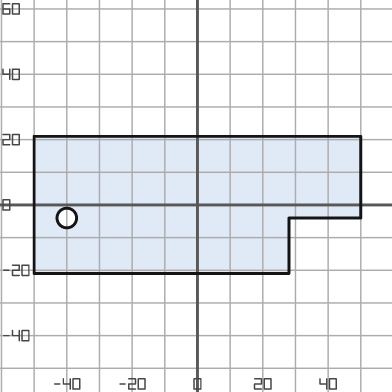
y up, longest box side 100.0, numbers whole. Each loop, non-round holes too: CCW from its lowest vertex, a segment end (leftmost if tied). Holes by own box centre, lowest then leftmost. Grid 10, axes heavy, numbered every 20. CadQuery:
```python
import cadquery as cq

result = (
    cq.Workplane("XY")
    .moveTo(-50.0, -21.0)
    .lineTo(28.0, -21.0)
    .lineTo(28.0, -4.0)
    .lineTo(50.0, -4.0)
    .lineTo(50.0, 21.0)
    .lineTo(-50.0, 21.0)
    .close()
    .moveTo(-40.0, -4.0)
    .circle(3.0)
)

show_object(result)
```